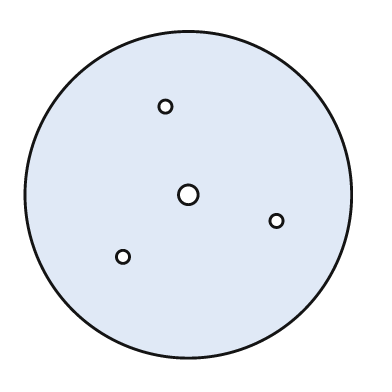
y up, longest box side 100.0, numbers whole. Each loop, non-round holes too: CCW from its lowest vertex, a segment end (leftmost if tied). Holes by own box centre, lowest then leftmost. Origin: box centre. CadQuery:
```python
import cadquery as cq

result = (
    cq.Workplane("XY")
    .moveTo(0.0, 0.0)
    .circle(50.0)
    .moveTo(-20.0, -19.0)
    .circle(2.0)
    .moveTo(27.0, -8.0)
    .circle(2.0)
    .moveTo(0.0, 0.0)
    .circle(3.0)
    .moveTo(-7.0, 27.0)
    .circle(2.0)
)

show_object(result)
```